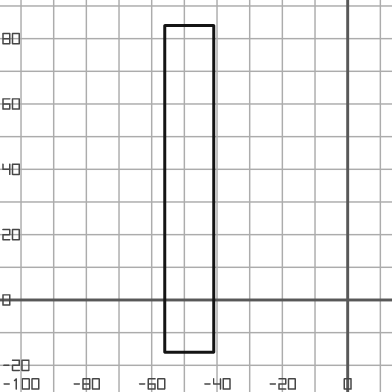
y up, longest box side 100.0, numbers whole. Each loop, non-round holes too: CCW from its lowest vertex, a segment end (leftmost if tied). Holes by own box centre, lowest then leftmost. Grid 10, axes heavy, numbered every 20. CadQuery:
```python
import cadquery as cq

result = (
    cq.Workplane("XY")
    .moveTo(-56.0, -16.0)
    .lineTo(-41.0, -16.0)
    .lineTo(-41.0, 84.0)
    .lineTo(-56.0, 84.0)
    .close()
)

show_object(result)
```